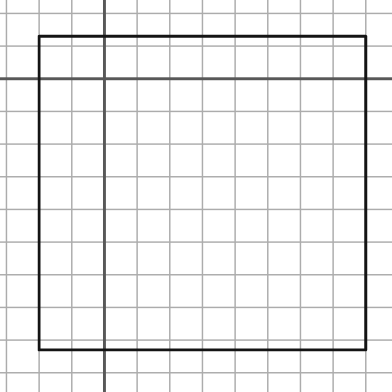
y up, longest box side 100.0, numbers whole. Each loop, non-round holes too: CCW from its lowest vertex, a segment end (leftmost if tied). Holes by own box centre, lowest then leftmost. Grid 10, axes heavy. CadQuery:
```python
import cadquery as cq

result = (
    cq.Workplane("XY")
    .moveTo(-20.0, -83.0)
    .lineTo(80.0, -83.0)
    .lineTo(80.0, 13.0)
    .lineTo(-20.0, 13.0)
    .close()
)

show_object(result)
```